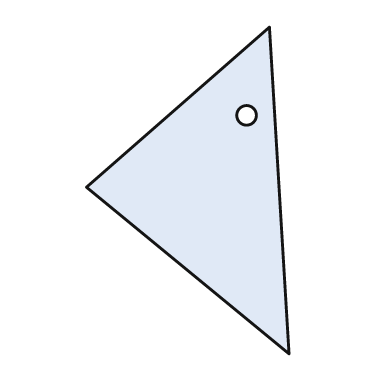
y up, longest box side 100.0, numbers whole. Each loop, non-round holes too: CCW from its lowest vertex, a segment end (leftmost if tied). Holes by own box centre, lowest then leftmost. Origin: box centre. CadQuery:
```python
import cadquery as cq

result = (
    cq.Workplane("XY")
    .moveTo(31.0, -50.0)
    .lineTo(25.0, 50.0)
    .lineTo(-31.0, 1.0)
    .close()
    .moveTo(18.0, 23.0)
    .circle(3.0)
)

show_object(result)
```